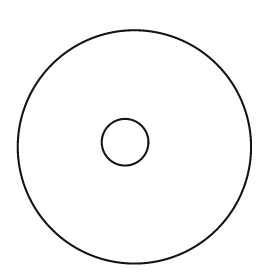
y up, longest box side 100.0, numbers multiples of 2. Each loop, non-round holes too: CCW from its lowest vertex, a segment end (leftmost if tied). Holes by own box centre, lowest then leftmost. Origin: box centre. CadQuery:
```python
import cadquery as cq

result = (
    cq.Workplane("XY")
    .moveTo(0.0, 0.0)
    .circle(50.0)
    .moveTo(-4.0, 2.0)
    .circle(10.0)
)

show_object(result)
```